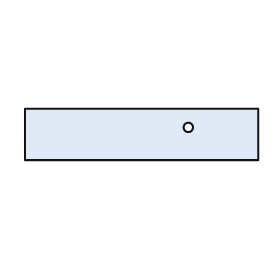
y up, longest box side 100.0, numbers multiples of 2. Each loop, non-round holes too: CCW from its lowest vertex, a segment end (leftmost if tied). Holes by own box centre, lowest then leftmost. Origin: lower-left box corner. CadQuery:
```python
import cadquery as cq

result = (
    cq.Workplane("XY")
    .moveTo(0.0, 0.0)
    .lineTo(100.0, 0.0)
    .lineTo(100.0, 22.0)
    .lineTo(0.0, 22.0)
    .close()
    .moveTo(70.0, 14.0)
    .circle(2.0)
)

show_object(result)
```